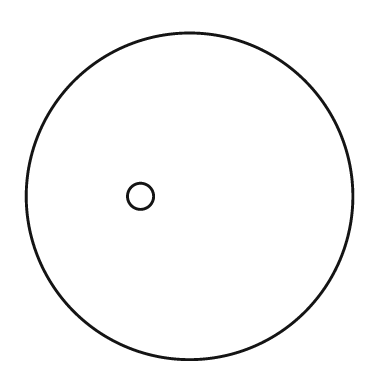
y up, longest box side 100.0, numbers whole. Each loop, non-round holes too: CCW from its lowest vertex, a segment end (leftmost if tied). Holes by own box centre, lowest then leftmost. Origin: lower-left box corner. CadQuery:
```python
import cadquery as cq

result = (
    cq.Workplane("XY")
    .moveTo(50.0, 50.0)
    .circle(50.0)
    .moveTo(35.0, 50.0)
    .circle(4.0)
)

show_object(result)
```